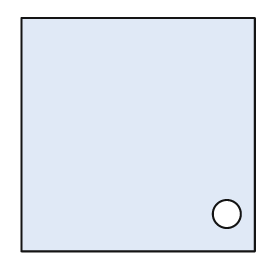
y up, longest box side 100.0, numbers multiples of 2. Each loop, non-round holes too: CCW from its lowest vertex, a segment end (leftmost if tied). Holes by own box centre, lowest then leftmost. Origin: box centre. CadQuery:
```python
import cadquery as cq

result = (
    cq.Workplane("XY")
    .moveTo(-50.0, -50.0)
    .lineTo(50.0, -50.0)
    .lineTo(50.0, 50.0)
    .lineTo(-50.0, 50.0)
    .close()
    .moveTo(38.0, -34.0)
    .circle(6.0)
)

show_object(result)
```